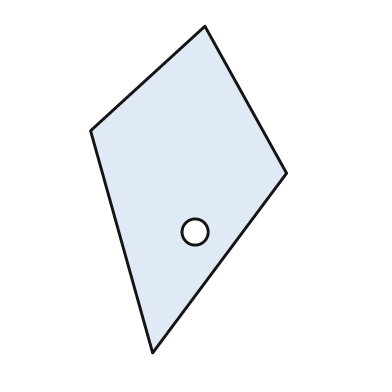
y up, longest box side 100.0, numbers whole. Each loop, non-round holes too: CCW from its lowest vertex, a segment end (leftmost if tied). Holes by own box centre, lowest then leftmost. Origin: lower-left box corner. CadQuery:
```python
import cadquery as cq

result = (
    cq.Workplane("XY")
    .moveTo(19.0, 0.0)
    .lineTo(60.0, 55.0)
    .lineTo(35.0, 100.0)
    .lineTo(0.0, 68.0)
    .close()
    .moveTo(32.0, 37.0)
    .circle(4.0)
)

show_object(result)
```